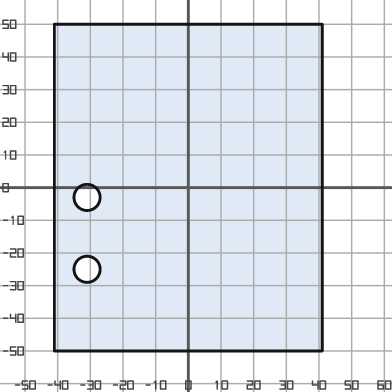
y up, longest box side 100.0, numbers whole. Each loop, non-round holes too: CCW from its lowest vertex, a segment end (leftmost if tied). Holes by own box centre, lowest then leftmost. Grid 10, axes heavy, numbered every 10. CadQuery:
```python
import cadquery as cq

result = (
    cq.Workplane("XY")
    .moveTo(-41.0, -50.0)
    .lineTo(41.0, -50.0)
    .lineTo(41.0, 50.0)
    .lineTo(-41.0, 50.0)
    .close()
    .moveTo(-31.0, -25.0)
    .circle(4.0)
    .moveTo(-31.0, -3.0)
    .circle(4.0)
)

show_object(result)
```